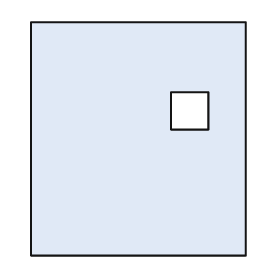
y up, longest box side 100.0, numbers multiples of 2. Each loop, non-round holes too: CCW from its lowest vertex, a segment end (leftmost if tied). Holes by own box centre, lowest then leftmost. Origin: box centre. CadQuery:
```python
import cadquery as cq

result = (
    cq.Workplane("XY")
    .moveTo(-46.0, -50.0)
    .lineTo(46.0, -50.0)
    .lineTo(46.0, 50.0)
    .lineTo(-46.0, 50.0)
    .close()
    .moveTo(14.0, 4.0)
    .lineTo(30.0, 4.0)
    .lineTo(30.0, 20.0)
    .lineTo(14.0, 20.0)
    .close()
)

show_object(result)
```